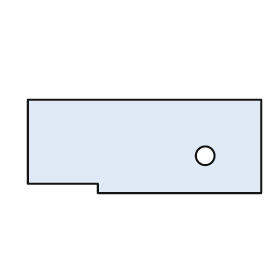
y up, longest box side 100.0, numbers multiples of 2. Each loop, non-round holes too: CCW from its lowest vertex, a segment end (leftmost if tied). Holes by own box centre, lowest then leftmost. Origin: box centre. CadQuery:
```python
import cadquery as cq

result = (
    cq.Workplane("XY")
    .moveTo(-20.0, -20.0)
    .lineTo(50.0, -20.0)
    .lineTo(50.0, 20.0)
    .lineTo(-50.0, 20.0)
    .lineTo(-50.0, -16.0)
    .lineTo(-20.0, -16.0)
    .close()
    .moveTo(26.0, -4.0)
    .circle(4.0)
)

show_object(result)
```